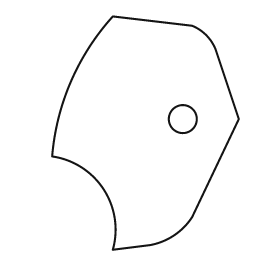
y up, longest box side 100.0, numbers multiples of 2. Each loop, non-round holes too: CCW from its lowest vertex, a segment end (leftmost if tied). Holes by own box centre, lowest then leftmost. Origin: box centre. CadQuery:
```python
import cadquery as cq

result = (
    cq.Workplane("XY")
    .moveTo(-14.0, -50.0)
    .lineTo(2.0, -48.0)
    .threePointArc((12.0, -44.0), (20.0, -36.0))
    .lineTo(40.0, 6.0)
    .lineTo(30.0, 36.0)
    .threePointArc((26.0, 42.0), (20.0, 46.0))
    .lineTo(-14.0, 50.0)
    .threePointArc((-32.0, 22.0), (-40.0, -10.0))
    .threePointArc((-18.0, -24.0), (-14.0, -50.0))
    .close()
    .moveTo(16.0, 6.0)
    .circle(6.0)
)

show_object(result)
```